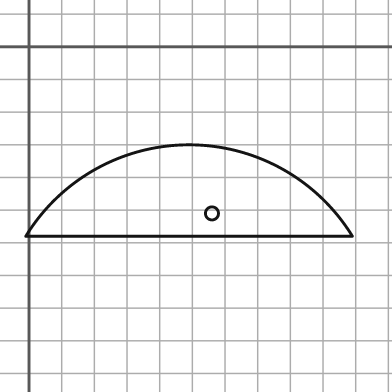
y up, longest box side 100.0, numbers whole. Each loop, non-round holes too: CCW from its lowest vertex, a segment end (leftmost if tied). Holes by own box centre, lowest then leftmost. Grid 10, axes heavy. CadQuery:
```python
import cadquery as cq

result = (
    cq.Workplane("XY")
    .moveTo(-1.0, -58.0)
    .lineTo(99.0, -58.0)
    .threePointArc((49.0, -30.0), (-1.0, -58.0))
    .close()
    .moveTo(56.0, -51.0)
    .circle(2.0)
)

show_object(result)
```